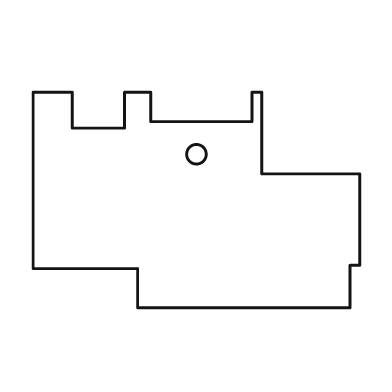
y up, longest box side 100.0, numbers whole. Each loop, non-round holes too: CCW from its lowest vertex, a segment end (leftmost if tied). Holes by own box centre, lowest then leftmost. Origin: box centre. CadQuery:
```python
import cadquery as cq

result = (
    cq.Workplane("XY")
    .moveTo(-18.0, -33.0)
    .lineTo(47.0, -33.0)
    .lineTo(47.0, -20.0)
    .lineTo(50.0, -20.0)
    .lineTo(50.0, 8.0)
    .lineTo(20.0, 8.0)
    .lineTo(20.0, 33.0)
    .lineTo(17.0, 33.0)
    .lineTo(17.0, 24.0)
    .lineTo(-14.0, 24.0)
    .lineTo(-14.0, 33.0)
    .lineTo(-22.0, 33.0)
    .lineTo(-22.0, 22.0)
    .lineTo(-38.0, 22.0)
    .lineTo(-38.0, 33.0)
    .lineTo(-50.0, 33.0)
    .lineTo(-50.0, -21.0)
    .lineTo(-18.0, -21.0)
    .close()
    .moveTo(0.0, 14.0)
    .circle(3.0)
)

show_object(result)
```